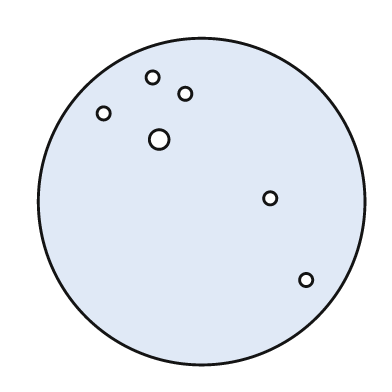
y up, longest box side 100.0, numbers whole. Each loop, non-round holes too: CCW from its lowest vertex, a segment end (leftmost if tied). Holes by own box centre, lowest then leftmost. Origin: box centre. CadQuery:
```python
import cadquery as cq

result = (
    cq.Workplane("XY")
    .moveTo(0.0, 0.0)
    .circle(50.0)
    .moveTo(32.0, -24.0)
    .circle(2.0)
    .moveTo(21.0, 1.0)
    .circle(2.0)
    .moveTo(-13.0, 19.0)
    .circle(3.0)
    .moveTo(-30.0, 27.0)
    .circle(2.0)
    .moveTo(-5.0, 33.0)
    .circle(2.0)
    .moveTo(-15.0, 38.0)
    .circle(2.0)
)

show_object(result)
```